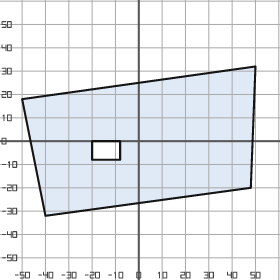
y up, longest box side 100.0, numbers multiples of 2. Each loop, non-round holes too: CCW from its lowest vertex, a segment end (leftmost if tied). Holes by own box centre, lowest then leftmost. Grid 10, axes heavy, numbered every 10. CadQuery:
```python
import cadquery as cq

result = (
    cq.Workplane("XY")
    .moveTo(-40.0, -32.0)
    .lineTo(48.0, -20.0)
    .lineTo(50.0, 32.0)
    .lineTo(-50.0, 18.0)
    .close()
    .moveTo(-20.0, -8.0)
    .lineTo(-8.0, -8.0)
    .lineTo(-8.0, 0.0)
    .lineTo(-20.0, 0.0)
    .close()
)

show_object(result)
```